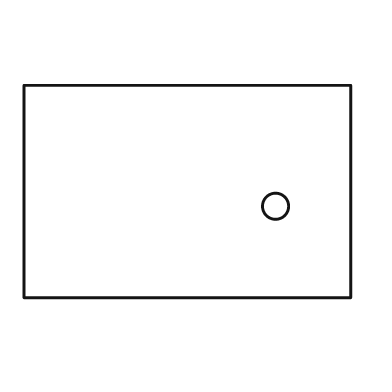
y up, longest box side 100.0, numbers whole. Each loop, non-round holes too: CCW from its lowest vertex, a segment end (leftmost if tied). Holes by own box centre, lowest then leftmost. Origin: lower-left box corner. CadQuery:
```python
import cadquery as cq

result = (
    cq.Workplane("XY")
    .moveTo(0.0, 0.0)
    .lineTo(100.0, 0.0)
    .lineTo(100.0, 65.0)
    .lineTo(0.0, 65.0)
    .close()
    .moveTo(77.0, 28.0)
    .circle(4.0)
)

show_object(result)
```